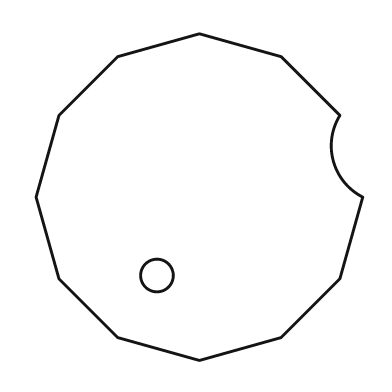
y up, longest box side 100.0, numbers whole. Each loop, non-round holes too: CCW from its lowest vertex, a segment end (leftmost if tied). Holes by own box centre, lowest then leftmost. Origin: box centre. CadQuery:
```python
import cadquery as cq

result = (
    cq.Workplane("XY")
    .moveTo(0.0, -50.0)
    .lineTo(25.0, -43.0)
    .lineTo(43.0, -25.0)
    .lineTo(50.0, 0.0)
    .threePointArc((41.0, 11.0), (43.0, 25.0))
    .lineTo(25.0, 43.0)
    .lineTo(0.0, 50.0)
    .lineTo(-25.0, 43.0)
    .lineTo(-43.0, 25.0)
    .lineTo(-50.0, 0.0)
    .lineTo(-43.0, -25.0)
    .lineTo(-25.0, -43.0)
    .close()
    .moveTo(-13.0, -24.0)
    .circle(5.0)
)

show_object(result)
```